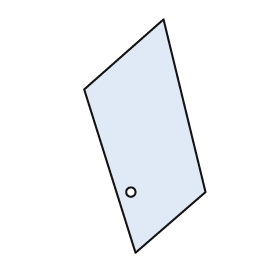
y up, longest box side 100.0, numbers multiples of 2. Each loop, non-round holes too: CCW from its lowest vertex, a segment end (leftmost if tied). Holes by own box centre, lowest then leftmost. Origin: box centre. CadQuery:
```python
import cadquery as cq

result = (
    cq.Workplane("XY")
    .moveTo(-4.0, -50.0)
    .lineTo(26.0, -24.0)
    .lineTo(8.0, 50.0)
    .lineTo(-26.0, 20.0)
    .close()
    .moveTo(-6.0, -24.0)
    .circle(2.0)
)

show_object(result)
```